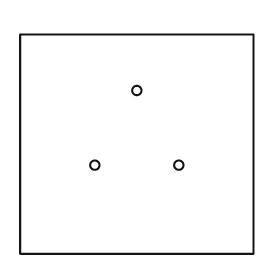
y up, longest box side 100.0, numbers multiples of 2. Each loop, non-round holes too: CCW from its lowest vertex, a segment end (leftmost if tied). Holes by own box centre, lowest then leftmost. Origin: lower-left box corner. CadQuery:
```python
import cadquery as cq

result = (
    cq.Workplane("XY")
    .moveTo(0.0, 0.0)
    .lineTo(100.0, 0.0)
    .lineTo(100.0, 94.0)
    .lineTo(0.0, 94.0)
    .close()
    .moveTo(32.0, 38.0)
    .circle(2.0)
    .moveTo(68.0, 38.0)
    .circle(2.0)
    .moveTo(50.0, 70.0)
    .circle(2.0)
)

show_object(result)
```